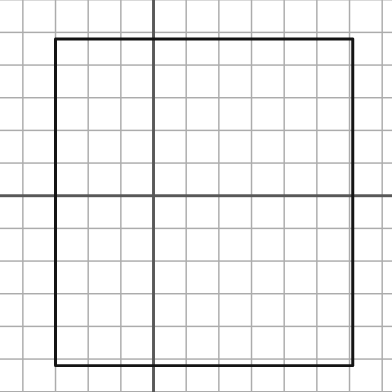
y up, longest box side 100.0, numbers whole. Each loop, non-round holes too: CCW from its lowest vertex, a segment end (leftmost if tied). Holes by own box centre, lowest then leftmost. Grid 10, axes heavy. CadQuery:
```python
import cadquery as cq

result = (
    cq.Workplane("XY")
    .moveTo(-30.0, -52.0)
    .lineTo(61.0, -52.0)
    .lineTo(61.0, 48.0)
    .lineTo(-30.0, 48.0)
    .close()
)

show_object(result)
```